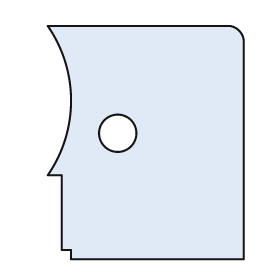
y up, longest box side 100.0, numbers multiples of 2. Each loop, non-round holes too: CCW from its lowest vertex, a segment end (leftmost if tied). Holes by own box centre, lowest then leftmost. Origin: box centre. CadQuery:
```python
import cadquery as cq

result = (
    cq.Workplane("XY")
    .moveTo(-32.0, -50.0)
    .lineTo(42.0, -50.0)
    .lineTo(42.0, 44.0)
    .threePointArc((40.0, 48.0), (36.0, 50.0))
    .lineTo(-42.0, 50.0)
    .threePointArc((-32.0, 18.0), (-42.0, -14.0))
    .lineTo(-36.0, -14.0)
    .lineTo(-36.0, -46.0)
    .lineTo(-32.0, -46.0)
    .close()
    .moveTo(-12.0, 4.0)
    .circle(8.0)
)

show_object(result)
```